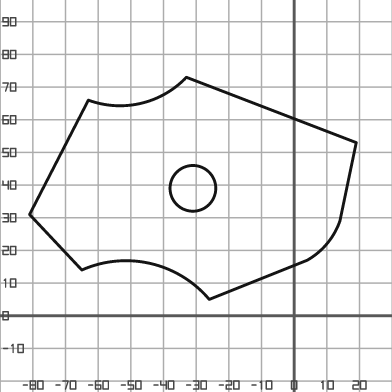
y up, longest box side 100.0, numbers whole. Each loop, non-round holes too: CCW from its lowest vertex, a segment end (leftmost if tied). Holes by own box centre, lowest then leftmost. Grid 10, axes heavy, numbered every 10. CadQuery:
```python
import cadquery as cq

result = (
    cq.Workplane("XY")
    .moveTo(-26.0, 5.0)
    .lineTo(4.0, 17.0)
    .threePointArc((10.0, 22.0), (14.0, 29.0))
    .lineTo(19.0, 53.0)
    .lineTo(-33.0, 73.0)
    .threePointArc((-47.0, 65.0), (-63.0, 66.0))
    .lineTo(-81.0, 31.0)
    .lineTo(-65.0, 14.0)
    .threePointArc((-44.0, 16.0), (-26.0, 5.0))
    .close()
    .moveTo(-31.0, 39.0)
    .circle(7.0)
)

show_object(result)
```